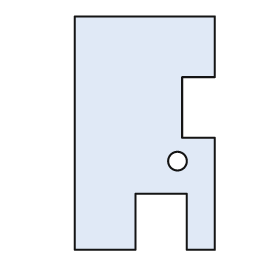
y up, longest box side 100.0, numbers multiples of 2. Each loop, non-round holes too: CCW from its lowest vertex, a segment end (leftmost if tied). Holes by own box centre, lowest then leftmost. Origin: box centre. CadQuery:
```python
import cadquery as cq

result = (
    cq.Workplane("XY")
    .moveTo(-30.0, -50.0)
    .lineTo(-4.0, -50.0)
    .lineTo(-4.0, -26.0)
    .lineTo(18.0, -26.0)
    .lineTo(18.0, -50.0)
    .lineTo(30.0, -50.0)
    .lineTo(30.0, -2.0)
    .lineTo(16.0, -2.0)
    .lineTo(16.0, 24.0)
    .lineTo(30.0, 24.0)
    .lineTo(30.0, 50.0)
    .lineTo(-30.0, 50.0)
    .close()
    .moveTo(14.0, -12.0)
    .circle(4.0)
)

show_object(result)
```